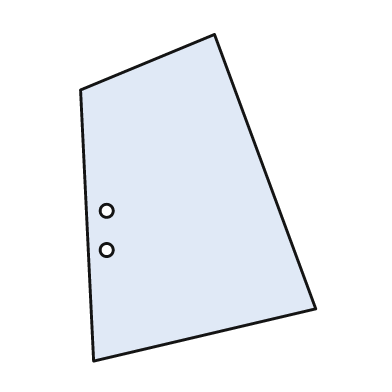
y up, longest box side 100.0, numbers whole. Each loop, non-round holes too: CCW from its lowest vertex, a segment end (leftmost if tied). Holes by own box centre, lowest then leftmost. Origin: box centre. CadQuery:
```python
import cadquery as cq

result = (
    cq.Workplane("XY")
    .moveTo(-32.0, -50.0)
    .lineTo(36.0, -34.0)
    .lineTo(5.0, 50.0)
    .lineTo(-36.0, 33.0)
    .close()
    .moveTo(-28.0, -16.0)
    .circle(2.0)
    .moveTo(-28.0, -4.0)
    .circle(2.0)
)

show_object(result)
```